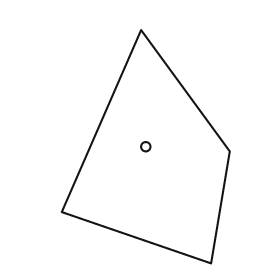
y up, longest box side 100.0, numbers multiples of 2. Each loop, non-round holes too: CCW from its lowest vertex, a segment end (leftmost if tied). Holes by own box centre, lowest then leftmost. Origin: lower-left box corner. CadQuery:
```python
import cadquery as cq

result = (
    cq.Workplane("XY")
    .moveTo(64.0, 0.0)
    .lineTo(72.0, 48.0)
    .lineTo(34.0, 100.0)
    .lineTo(0.0, 22.0)
    .close()
    .moveTo(36.0, 50.0)
    .circle(2.0)
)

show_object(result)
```